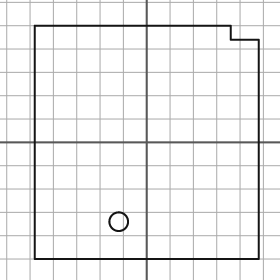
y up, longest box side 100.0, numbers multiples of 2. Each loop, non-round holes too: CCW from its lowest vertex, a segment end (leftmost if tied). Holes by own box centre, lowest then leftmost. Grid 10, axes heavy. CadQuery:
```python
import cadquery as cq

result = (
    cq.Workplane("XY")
    .moveTo(-48.0, -50.0)
    .lineTo(48.0, -50.0)
    .lineTo(48.0, 44.0)
    .lineTo(36.0, 44.0)
    .lineTo(36.0, 50.0)
    .lineTo(-48.0, 50.0)
    .close()
    .moveTo(-12.0, -34.0)
    .circle(4.0)
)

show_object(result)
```